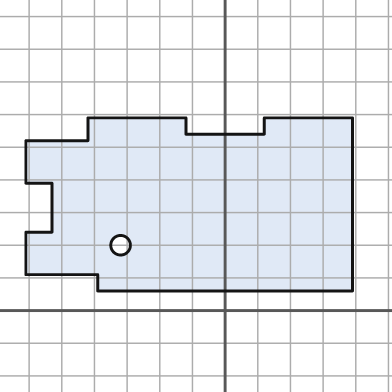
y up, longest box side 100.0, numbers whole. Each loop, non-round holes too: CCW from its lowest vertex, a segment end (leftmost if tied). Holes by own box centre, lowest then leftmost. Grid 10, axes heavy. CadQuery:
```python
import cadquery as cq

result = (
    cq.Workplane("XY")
    .moveTo(-39.0, 6.0)
    .lineTo(39.0, 6.0)
    .lineTo(39.0, 59.0)
    .lineTo(12.0, 59.0)
    .lineTo(12.0, 54.0)
    .lineTo(-12.0, 54.0)
    .lineTo(-12.0, 59.0)
    .lineTo(-42.0, 59.0)
    .lineTo(-42.0, 52.0)
    .lineTo(-61.0, 52.0)
    .lineTo(-61.0, 39.0)
    .lineTo(-53.0, 39.0)
    .lineTo(-53.0, 24.0)
    .lineTo(-61.0, 24.0)
    .lineTo(-61.0, 11.0)
    .lineTo(-39.0, 11.0)
    .close()
    .moveTo(-32.0, 20.0)
    .circle(3.0)
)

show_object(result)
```